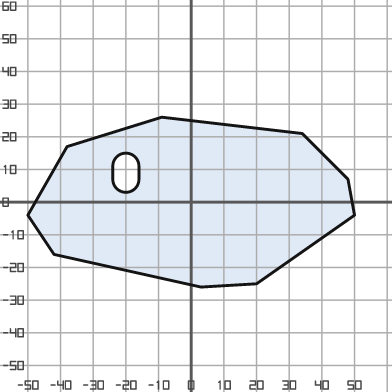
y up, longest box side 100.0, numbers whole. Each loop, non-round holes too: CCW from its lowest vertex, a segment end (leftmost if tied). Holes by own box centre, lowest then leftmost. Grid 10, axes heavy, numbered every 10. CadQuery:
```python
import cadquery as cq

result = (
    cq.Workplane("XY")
    .moveTo(3.0, -26.0)
    .lineTo(20.0, -25.0)
    .lineTo(50.0, -4.0)
    .lineTo(48.0, 7.0)
    .lineTo(34.0, 21.0)
    .lineTo(-9.0, 26.0)
    .lineTo(-38.0, 17.0)
    .lineTo(-50.0, -4.0)
    .lineTo(-42.0, -16.0)
    .close()
    .moveTo(-24.0, 7.0)
    .threePointArc((-20.0, 3.0), (-16.0, 7.0))
    .lineTo(-16.0, 11.0)
    .threePointArc((-20.0, 15.0), (-24.0, 11.0))
    .close()
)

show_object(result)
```